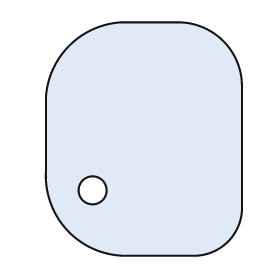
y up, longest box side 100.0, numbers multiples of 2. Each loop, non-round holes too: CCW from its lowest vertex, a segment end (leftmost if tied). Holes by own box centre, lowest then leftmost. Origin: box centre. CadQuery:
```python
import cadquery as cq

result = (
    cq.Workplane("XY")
    .moveTo(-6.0, -50.0)
    .lineTo(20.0, -50.0)
    .threePointArc((36.0, -44.0), (42.0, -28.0))
    .lineTo(42.0, 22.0)
    .threePointArc((34.0, 42.0), (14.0, 50.0))
    .lineTo(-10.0, 50.0)
    .threePointArc((-32.0, 40.0), (-42.0, 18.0))
    .lineTo(-42.0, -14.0)
    .threePointArc((-32.0, -40.0), (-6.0, -50.0))
    .close()
    .moveTo(-22.0, -22.0)
    .circle(6.0)
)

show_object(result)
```